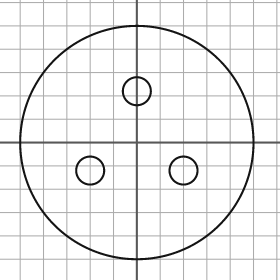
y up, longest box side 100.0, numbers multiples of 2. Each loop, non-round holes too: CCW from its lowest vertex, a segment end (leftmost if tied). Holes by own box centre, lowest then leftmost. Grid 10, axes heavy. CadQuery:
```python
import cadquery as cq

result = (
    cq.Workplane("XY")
    .moveTo(0.0, 0.0)
    .circle(50.0)
    .moveTo(-20.0, -12.0)
    .circle(6.0)
    .moveTo(20.0, -12.0)
    .circle(6.0)
    .moveTo(0.0, 22.0)
    .circle(6.0)
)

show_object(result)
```